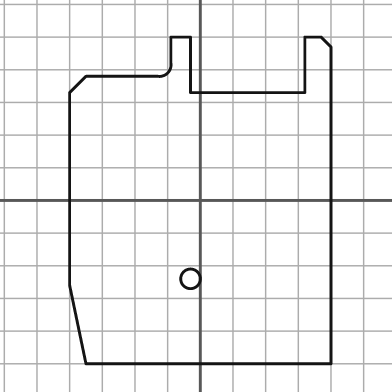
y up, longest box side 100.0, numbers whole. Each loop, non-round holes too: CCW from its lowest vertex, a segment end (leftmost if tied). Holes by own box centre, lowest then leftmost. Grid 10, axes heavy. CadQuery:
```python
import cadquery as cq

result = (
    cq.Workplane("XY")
    .moveTo(-35.0, -50.0)
    .lineTo(40.0, -50.0)
    .lineTo(40.0, 47.0)
    .lineTo(37.0, 50.0)
    .lineTo(32.0, 50.0)
    .lineTo(32.0, 33.0)
    .lineTo(-3.0, 33.0)
    .lineTo(-3.0, 50.0)
    .lineTo(-9.0, 50.0)
    .lineTo(-9.0, 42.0)
    .threePointArc((-10.0, 39.0), (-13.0, 38.0))
    .lineTo(-35.0, 38.0)
    .lineTo(-40.0, 33.0)
    .lineTo(-40.0, -26.0)
    .close()
    .moveTo(-3.0, -24.0)
    .circle(3.0)
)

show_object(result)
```